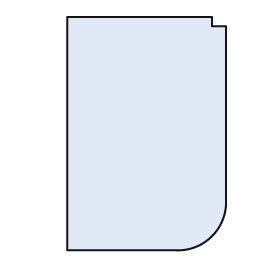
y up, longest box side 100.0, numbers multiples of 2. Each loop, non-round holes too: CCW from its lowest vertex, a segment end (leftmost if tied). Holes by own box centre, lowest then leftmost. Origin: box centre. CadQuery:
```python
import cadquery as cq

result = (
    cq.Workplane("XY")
    .moveTo(-34.0, -50.0)
    .lineTo(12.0, -50.0)
    .threePointArc((28.0, -44.0), (34.0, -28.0))
    .lineTo(34.0, 46.0)
    .lineTo(28.0, 46.0)
    .lineTo(28.0, 50.0)
    .lineTo(-34.0, 50.0)
    .close()
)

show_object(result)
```